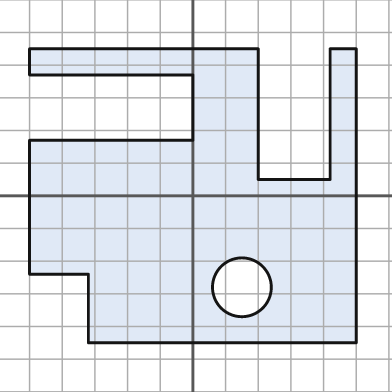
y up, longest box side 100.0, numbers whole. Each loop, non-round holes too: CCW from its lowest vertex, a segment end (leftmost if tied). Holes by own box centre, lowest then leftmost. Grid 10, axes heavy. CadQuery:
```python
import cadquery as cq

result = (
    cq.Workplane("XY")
    .moveTo(-32.0, -45.0)
    .lineTo(50.0, -45.0)
    .lineTo(50.0, 45.0)
    .lineTo(42.0, 45.0)
    .lineTo(42.0, 5.0)
    .lineTo(20.0, 5.0)
    .lineTo(20.0, 45.0)
    .lineTo(-50.0, 45.0)
    .lineTo(-50.0, 37.0)
    .lineTo(0.0, 37.0)
    .lineTo(0.0, 17.0)
    .lineTo(-50.0, 17.0)
    .lineTo(-50.0, -24.0)
    .lineTo(-32.0, -24.0)
    .close()
    .moveTo(15.0, -28.0)
    .circle(9.0)
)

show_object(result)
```